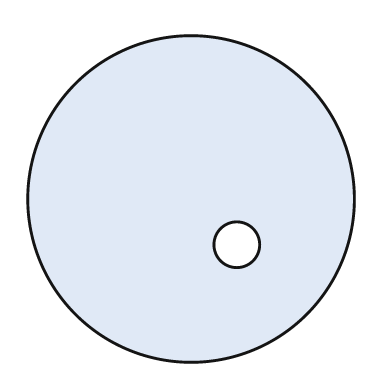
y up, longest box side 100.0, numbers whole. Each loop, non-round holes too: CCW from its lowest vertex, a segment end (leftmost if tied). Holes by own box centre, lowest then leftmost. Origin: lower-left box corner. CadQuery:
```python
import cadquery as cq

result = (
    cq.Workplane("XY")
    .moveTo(50.0, 50.0)
    .circle(50.0)
    .moveTo(64.0, 36.0)
    .circle(7.0)
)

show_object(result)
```